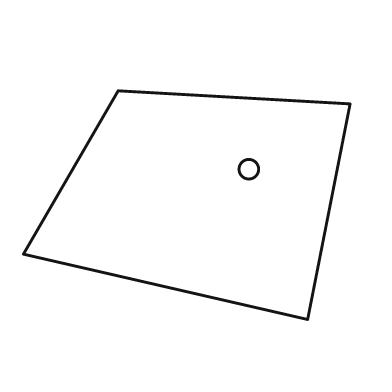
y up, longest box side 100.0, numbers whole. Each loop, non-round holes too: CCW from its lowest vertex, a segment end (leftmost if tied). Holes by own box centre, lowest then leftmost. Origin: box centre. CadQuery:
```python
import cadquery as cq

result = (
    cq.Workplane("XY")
    .moveTo(37.0, -35.0)
    .lineTo(50.0, 31.0)
    .lineTo(-21.0, 35.0)
    .lineTo(-50.0, -15.0)
    .close()
    .moveTo(19.0, 11.0)
    .circle(3.0)
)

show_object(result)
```